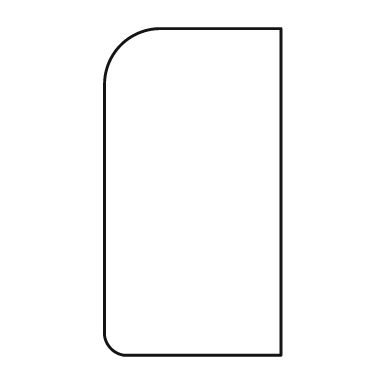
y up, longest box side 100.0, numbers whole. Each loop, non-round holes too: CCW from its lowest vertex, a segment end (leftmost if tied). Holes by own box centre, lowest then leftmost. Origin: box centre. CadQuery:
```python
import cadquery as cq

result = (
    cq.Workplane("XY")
    .moveTo(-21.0, -50.0)
    .lineTo(27.0, -50.0)
    .lineTo(27.0, 50.0)
    .lineTo(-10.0, 50.0)
    .threePointArc((-22.0, 45.0), (-27.0, 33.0))
    .lineTo(-27.0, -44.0)
    .threePointArc((-25.0, -48.0), (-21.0, -50.0))
    .close()
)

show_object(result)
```